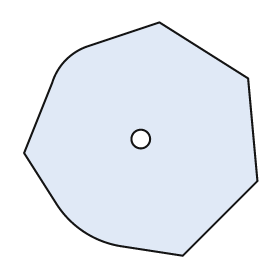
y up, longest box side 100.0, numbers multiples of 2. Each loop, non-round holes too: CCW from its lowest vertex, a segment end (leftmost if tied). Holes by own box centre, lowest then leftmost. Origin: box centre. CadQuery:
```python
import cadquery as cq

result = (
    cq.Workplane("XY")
    .moveTo(18.0, -50.0)
    .lineTo(50.0, -18.0)
    .lineTo(46.0, 26.0)
    .lineTo(8.0, 50.0)
    .lineTo(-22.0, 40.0)
    .threePointArc((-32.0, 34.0), (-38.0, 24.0))
    .lineTo(-50.0, -6.0)
    .lineTo(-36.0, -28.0)
    .threePointArc((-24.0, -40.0), (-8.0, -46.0))
    .close()
    .moveTo(0.0, 0.0)
    .circle(4.0)
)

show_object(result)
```